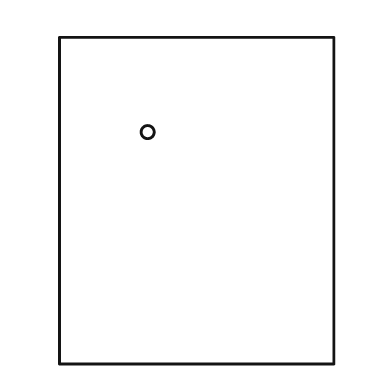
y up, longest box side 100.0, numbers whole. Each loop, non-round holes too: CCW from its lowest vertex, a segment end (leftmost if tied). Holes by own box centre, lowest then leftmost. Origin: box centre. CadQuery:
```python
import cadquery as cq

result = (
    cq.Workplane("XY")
    .moveTo(-42.0, -50.0)
    .lineTo(42.0, -50.0)
    .lineTo(42.0, 50.0)
    .lineTo(-42.0, 50.0)
    .close()
    .moveTo(-15.0, 21.0)
    .circle(2.0)
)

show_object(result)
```